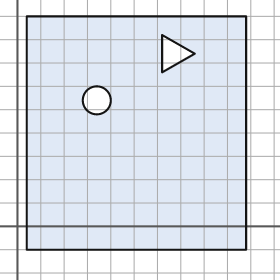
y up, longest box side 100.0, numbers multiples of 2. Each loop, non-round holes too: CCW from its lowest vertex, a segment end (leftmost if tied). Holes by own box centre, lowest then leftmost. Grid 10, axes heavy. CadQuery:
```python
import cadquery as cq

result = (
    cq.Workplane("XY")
    .moveTo(4.0, -10.0)
    .lineTo(98.0, -10.0)
    .lineTo(98.0, 90.0)
    .lineTo(4.0, 90.0)
    .close()
    .moveTo(34.0, 54.0)
    .circle(6.0)
    .moveTo(62.0, 66.0)
    .lineTo(76.0, 74.0)
    .lineTo(62.0, 82.0)
    .close()
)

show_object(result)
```